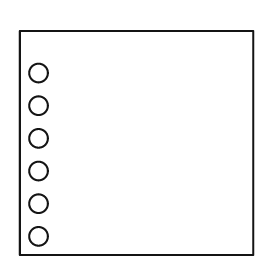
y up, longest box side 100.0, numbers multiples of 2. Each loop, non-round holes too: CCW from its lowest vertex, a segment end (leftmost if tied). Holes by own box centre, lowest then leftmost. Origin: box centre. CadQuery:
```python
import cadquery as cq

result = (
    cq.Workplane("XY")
    .moveTo(-50.0, -48.0)
    .lineTo(50.0, -48.0)
    .lineTo(50.0, 48.0)
    .lineTo(-50.0, 48.0)
    .close()
    .moveTo(-42.0, -40.0)
    .circle(4.0)
    .moveTo(-42.0, -26.0)
    .circle(4.0)
    .moveTo(-42.0, -12.0)
    .circle(4.0)
    .moveTo(-42.0, 2.0)
    .circle(4.0)
    .moveTo(-42.0, 16.0)
    .circle(4.0)
    .moveTo(-42.0, 30.0)
    .circle(4.0)
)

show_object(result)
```